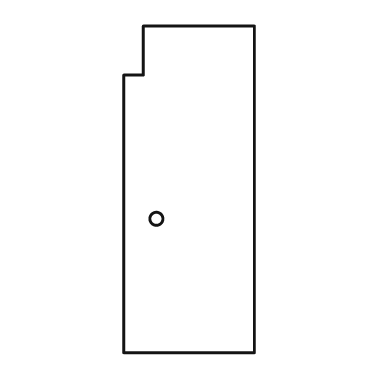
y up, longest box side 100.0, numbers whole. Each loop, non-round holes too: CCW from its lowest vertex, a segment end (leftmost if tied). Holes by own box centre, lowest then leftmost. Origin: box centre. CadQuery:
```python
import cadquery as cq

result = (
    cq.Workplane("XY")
    .moveTo(-20.0, -50.0)
    .lineTo(20.0, -50.0)
    .lineTo(20.0, 50.0)
    .lineTo(-14.0, 50.0)
    .lineTo(-14.0, 35.0)
    .lineTo(-20.0, 35.0)
    .close()
    .moveTo(-10.0, -9.0)
    .circle(2.0)
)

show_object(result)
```